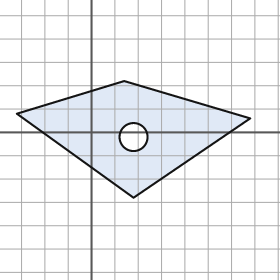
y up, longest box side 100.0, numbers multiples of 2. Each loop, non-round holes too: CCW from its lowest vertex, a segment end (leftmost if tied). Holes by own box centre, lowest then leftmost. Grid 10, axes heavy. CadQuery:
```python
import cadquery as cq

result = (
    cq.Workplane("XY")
    .moveTo(18.0, -28.0)
    .lineTo(68.0, 6.0)
    .lineTo(14.0, 22.0)
    .lineTo(-32.0, 8.0)
    .close()
    .moveTo(18.0, -2.0)
    .circle(6.0)
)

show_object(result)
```